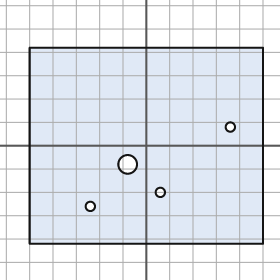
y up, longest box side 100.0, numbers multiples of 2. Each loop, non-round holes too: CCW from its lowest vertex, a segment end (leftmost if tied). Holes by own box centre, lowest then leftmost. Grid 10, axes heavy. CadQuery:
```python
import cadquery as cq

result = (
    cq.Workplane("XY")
    .moveTo(-50.0, -42.0)
    .lineTo(50.0, -42.0)
    .lineTo(50.0, 42.0)
    .lineTo(-50.0, 42.0)
    .close()
    .moveTo(-24.0, -26.0)
    .circle(2.0)
    .moveTo(6.0, -20.0)
    .circle(2.0)
    .moveTo(-8.0, -8.0)
    .circle(4.0)
    .moveTo(36.0, 8.0)
    .circle(2.0)
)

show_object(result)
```